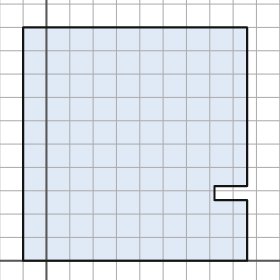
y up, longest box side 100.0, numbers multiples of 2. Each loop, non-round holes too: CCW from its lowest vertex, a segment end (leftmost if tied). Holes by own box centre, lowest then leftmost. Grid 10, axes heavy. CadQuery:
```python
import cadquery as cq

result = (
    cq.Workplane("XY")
    .moveTo(-10.0, 0.0)
    .lineTo(86.0, 0.0)
    .lineTo(86.0, 26.0)
    .lineTo(72.0, 26.0)
    .lineTo(72.0, 32.0)
    .lineTo(86.0, 32.0)
    .lineTo(86.0, 100.0)
    .lineTo(-10.0, 100.0)
    .close()
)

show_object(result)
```